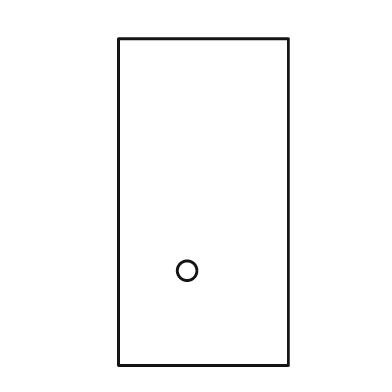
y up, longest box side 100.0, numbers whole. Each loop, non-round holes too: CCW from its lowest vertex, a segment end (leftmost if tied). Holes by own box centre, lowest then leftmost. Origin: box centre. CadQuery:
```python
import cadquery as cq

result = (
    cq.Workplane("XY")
    .moveTo(-26.0, -50.0)
    .lineTo(26.0, -50.0)
    .lineTo(26.0, 50.0)
    .lineTo(-26.0, 50.0)
    .close()
    .moveTo(-5.0, -21.0)
    .circle(3.0)
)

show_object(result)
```